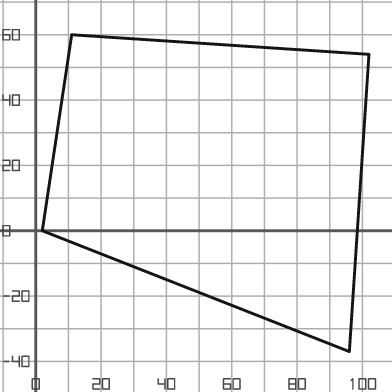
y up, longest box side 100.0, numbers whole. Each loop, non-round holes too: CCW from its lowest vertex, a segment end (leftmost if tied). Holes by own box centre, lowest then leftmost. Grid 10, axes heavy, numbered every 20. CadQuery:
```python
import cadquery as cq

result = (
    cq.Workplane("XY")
    .moveTo(96.0, -37.0)
    .lineTo(102.0, 54.0)
    .lineTo(11.0, 60.0)
    .lineTo(2.0, 0.0)
    .close()
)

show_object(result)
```